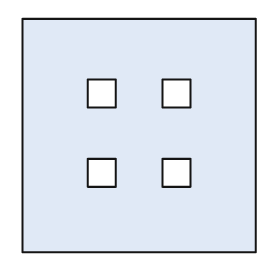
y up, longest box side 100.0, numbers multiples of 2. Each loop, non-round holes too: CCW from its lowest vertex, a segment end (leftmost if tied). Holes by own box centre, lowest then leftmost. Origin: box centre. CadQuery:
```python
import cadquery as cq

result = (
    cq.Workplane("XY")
    .moveTo(-50.0, -50.0)
    .lineTo(50.0, -50.0)
    .lineTo(50.0, 50.0)
    .lineTo(-50.0, 50.0)
    .close()
    .moveTo(-22.0, -22.0)
    .lineTo(-10.0, -22.0)
    .lineTo(-10.0, -10.0)
    .lineTo(-22.0, -10.0)
    .close()
    .moveTo(10.0, -22.0)
    .lineTo(22.0, -22.0)
    .lineTo(22.0, -10.0)
    .lineTo(10.0, -10.0)
    .close()
    .moveTo(-22.0, 12.0)
    .lineTo(-10.0, 12.0)
    .lineTo(-10.0, 24.0)
    .lineTo(-22.0, 24.0)
    .close()
    .moveTo(10.0, 12.0)
    .lineTo(22.0, 12.0)
    .lineTo(22.0, 24.0)
    .lineTo(10.0, 24.0)
    .close()
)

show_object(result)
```